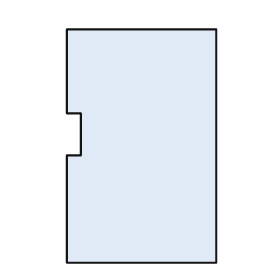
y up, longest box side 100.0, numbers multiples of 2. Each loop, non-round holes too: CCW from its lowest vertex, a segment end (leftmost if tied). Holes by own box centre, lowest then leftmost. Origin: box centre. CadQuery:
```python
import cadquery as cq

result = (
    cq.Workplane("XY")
    .moveTo(-32.0, -50.0)
    .lineTo(32.0, -50.0)
    .lineTo(32.0, 50.0)
    .lineTo(-32.0, 50.0)
    .lineTo(-32.0, 14.0)
    .lineTo(-26.0, 14.0)
    .lineTo(-26.0, -4.0)
    .lineTo(-32.0, -4.0)
    .close()
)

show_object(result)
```